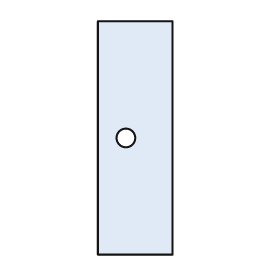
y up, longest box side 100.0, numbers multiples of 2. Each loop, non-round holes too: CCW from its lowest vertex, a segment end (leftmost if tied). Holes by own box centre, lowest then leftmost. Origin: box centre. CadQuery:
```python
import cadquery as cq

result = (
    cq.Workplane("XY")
    .moveTo(-16.0, -50.0)
    .lineTo(16.0, -50.0)
    .lineTo(16.0, 50.0)
    .lineTo(-16.0, 50.0)
    .close()
    .moveTo(-4.0, 0.0)
    .circle(4.0)
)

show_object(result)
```